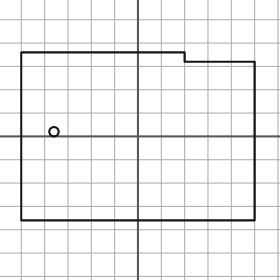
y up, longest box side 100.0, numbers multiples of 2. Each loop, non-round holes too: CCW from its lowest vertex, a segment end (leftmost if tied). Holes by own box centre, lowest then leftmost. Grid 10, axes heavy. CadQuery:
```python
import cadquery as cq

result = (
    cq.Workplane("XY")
    .moveTo(-50.0, -36.0)
    .lineTo(50.0, -36.0)
    .lineTo(50.0, 32.0)
    .lineTo(20.0, 32.0)
    .lineTo(20.0, 36.0)
    .lineTo(-50.0, 36.0)
    .close()
    .moveTo(-36.0, 2.0)
    .circle(2.0)
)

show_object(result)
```